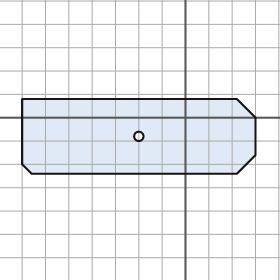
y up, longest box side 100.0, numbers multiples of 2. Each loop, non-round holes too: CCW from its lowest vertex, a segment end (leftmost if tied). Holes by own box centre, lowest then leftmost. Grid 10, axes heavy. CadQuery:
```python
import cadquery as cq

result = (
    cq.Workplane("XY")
    .moveTo(-66.0, -24.0)
    .lineTo(22.0, -24.0)
    .lineTo(30.0, -16.0)
    .lineTo(30.0, 0.0)
    .lineTo(22.0, 8.0)
    .lineTo(-70.0, 8.0)
    .lineTo(-70.0, -20.0)
    .close()
    .moveTo(-20.0, -8.0)
    .circle(2.0)
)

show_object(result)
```